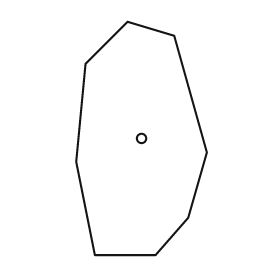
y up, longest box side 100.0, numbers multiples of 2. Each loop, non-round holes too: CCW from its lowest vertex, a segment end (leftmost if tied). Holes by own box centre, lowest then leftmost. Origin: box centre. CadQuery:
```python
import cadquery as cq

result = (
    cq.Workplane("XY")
    .moveTo(-20.0, -50.0)
    .lineTo(6.0, -50.0)
    .lineTo(20.0, -34.0)
    .lineTo(28.0, -6.0)
    .lineTo(14.0, 44.0)
    .lineTo(-6.0, 50.0)
    .lineTo(-24.0, 32.0)
    .lineTo(-28.0, -10.0)
    .close()
    .moveTo(0.0, 0.0)
    .circle(2.0)
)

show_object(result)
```